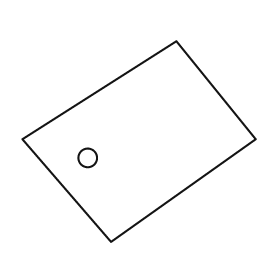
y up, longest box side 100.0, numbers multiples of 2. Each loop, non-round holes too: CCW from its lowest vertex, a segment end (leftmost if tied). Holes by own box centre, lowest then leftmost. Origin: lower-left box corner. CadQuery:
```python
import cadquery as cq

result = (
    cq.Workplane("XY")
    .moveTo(38.0, 0.0)
    .lineTo(100.0, 44.0)
    .lineTo(66.0, 86.0)
    .lineTo(0.0, 44.0)
    .close()
    .moveTo(28.0, 36.0)
    .circle(4.0)
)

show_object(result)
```